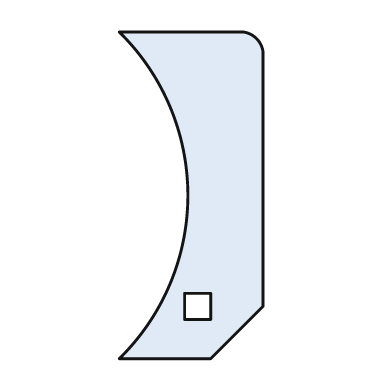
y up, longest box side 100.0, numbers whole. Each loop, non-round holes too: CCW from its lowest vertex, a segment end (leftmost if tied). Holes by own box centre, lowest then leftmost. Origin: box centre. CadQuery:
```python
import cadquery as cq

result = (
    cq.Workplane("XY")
    .moveTo(-22.0, -50.0)
    .lineTo(6.0, -50.0)
    .lineTo(22.0, -34.0)
    .lineTo(22.0, 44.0)
    .threePointArc((20.0, 48.0), (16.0, 50.0))
    .lineTo(-22.0, 50.0)
    .threePointArc((-1.0, 0.0), (-22.0, -50.0))
    .close()
    .moveTo(-2.0, -38.0)
    .lineTo(6.0, -38.0)
    .lineTo(6.0, -30.0)
    .lineTo(-2.0, -30.0)
    .close()
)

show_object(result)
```